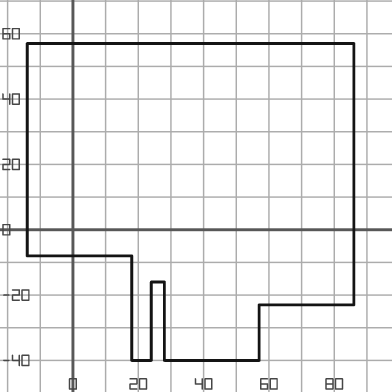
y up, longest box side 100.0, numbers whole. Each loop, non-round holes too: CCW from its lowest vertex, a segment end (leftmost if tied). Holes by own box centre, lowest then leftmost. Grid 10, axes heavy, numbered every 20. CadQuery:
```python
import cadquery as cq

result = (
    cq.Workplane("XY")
    .moveTo(18.0, -40.0)
    .lineTo(24.0, -40.0)
    .lineTo(24.0, -16.0)
    .lineTo(28.0, -16.0)
    .lineTo(28.0, -40.0)
    .lineTo(57.0, -40.0)
    .lineTo(57.0, -23.0)
    .lineTo(86.0, -23.0)
    .lineTo(86.0, 57.0)
    .lineTo(-14.0, 57.0)
    .lineTo(-14.0, -8.0)
    .lineTo(18.0, -8.0)
    .close()
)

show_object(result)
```